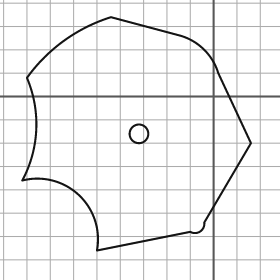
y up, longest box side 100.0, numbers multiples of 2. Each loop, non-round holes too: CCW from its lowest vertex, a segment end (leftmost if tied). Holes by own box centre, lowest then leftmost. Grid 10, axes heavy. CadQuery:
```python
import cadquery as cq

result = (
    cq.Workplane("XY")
    .moveTo(-50.0, -66.0)
    .lineTo(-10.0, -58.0)
    .threePointArc((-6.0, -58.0), (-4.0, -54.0))
    .lineTo(16.0, -20.0)
    .lineTo(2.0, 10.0)
    .threePointArc((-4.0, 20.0), (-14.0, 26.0))
    .lineTo(-44.0, 34.0)
    .threePointArc((-64.0, 24.0), (-80.0, 8.0))
    .threePointArc((-76.0, -14.0), (-82.0, -36.0))
    .threePointArc((-58.0, -42.0), (-50.0, -66.0))
    .close()
    .moveTo(-32.0, -16.0)
    .circle(4.0)
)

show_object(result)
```